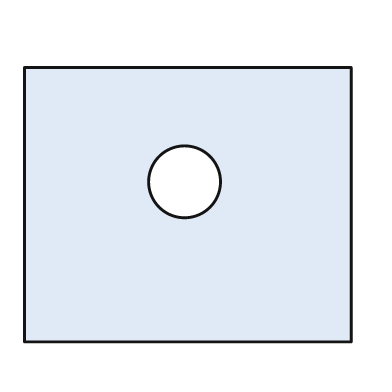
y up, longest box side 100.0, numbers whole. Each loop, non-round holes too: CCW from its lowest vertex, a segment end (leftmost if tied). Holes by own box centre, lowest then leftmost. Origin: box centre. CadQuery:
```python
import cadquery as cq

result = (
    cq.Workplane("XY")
    .moveTo(-50.0, -42.0)
    .lineTo(50.0, -42.0)
    .lineTo(50.0, 42.0)
    .lineTo(-50.0, 42.0)
    .close()
    .moveTo(-1.0, 7.0)
    .circle(11.0)
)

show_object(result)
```